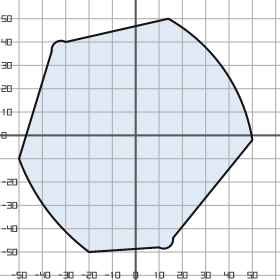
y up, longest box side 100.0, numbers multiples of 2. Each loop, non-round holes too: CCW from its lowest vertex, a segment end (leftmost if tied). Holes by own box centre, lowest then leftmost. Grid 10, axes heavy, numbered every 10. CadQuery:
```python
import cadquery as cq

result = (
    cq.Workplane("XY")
    .moveTo(-20.0, -50.0)
    .lineTo(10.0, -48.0)
    .threePointArc((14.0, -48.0), (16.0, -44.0))
    .lineTo(50.0, -2.0)
    .threePointArc((38.0, 28.0), (14.0, 50.0))
    .lineTo(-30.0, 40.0)
    .threePointArc((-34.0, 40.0), (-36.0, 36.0))
    .lineTo(-50.0, -10.0)
    .threePointArc((-38.0, -32.0), (-20.0, -50.0))
    .close()
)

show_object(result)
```